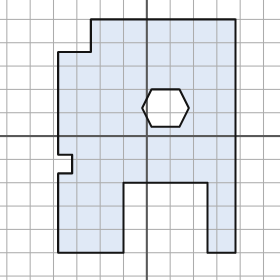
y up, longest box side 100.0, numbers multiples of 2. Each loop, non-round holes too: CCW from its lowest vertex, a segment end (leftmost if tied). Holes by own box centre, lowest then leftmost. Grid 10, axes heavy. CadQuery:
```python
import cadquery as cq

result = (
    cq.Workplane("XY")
    .moveTo(-38.0, -50.0)
    .lineTo(-10.0, -50.0)
    .lineTo(-10.0, -20.0)
    .lineTo(26.0, -20.0)
    .lineTo(26.0, -50.0)
    .lineTo(38.0, -50.0)
    .lineTo(38.0, 50.0)
    .lineTo(-24.0, 50.0)
    .lineTo(-24.0, 36.0)
    .lineTo(-38.0, 36.0)
    .lineTo(-38.0, -8.0)
    .lineTo(-32.0, -8.0)
    .lineTo(-32.0, -16.0)
    .lineTo(-38.0, -16.0)
    .close()
    .moveTo(2.0, 4.0)
    .lineTo(14.0, 4.0)
    .lineTo(18.0, 12.0)
    .lineTo(14.0, 20.0)
    .lineTo(2.0, 20.0)
    .lineTo(-2.0, 12.0)
    .close()
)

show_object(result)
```